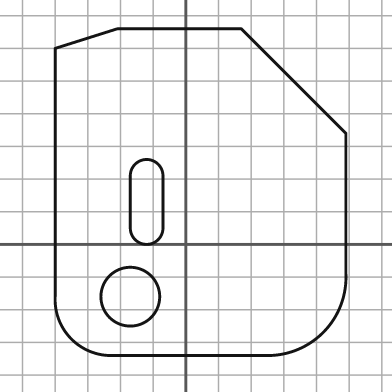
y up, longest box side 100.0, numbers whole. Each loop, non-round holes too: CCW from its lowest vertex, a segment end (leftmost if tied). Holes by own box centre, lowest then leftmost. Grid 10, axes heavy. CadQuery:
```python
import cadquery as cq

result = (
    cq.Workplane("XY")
    .moveTo(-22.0, -34.0)
    .lineTo(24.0, -34.0)
    .threePointArc((42.0, -27.0), (49.0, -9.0))
    .lineTo(49.0, 34.0)
    .lineTo(17.0, 66.0)
    .lineTo(-21.0, 66.0)
    .lineTo(-40.0, 60.0)
    .lineTo(-40.0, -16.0)
    .threePointArc((-35.0, -29.0), (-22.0, -34.0))
    .close()
    .moveTo(-17.0, -16.0)
    .circle(9.0)
    .moveTo(-17.0, 5.0)
    .threePointArc((-12.0, 0.0), (-7.0, 5.0))
    .lineTo(-7.0, 21.0)
    .threePointArc((-12.0, 26.0), (-17.0, 21.0))
    .close()
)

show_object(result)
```